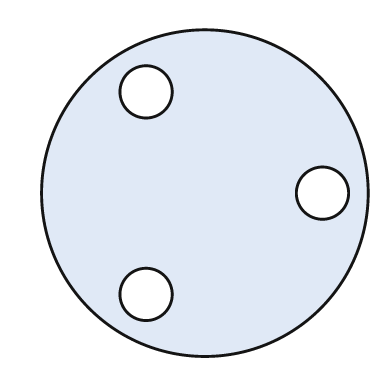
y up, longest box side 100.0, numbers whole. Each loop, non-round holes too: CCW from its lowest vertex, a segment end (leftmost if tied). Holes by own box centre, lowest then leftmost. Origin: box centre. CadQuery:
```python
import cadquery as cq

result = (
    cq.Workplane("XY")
    .moveTo(0.0, 0.0)
    .circle(50.0)
    .moveTo(-18.0, -31.0)
    .circle(8.0)
    .moveTo(36.0, 0.0)
    .circle(8.0)
    .moveTo(-18.0, 31.0)
    .circle(8.0)
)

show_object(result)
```